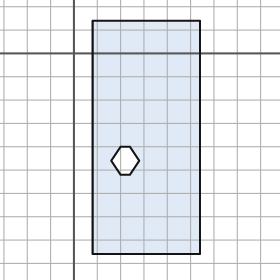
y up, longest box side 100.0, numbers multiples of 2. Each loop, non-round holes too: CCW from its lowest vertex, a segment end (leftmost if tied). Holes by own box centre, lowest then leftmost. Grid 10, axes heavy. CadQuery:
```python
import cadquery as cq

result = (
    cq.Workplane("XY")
    .moveTo(8.0, -86.0)
    .lineTo(54.0, -86.0)
    .lineTo(54.0, 14.0)
    .lineTo(8.0, 14.0)
    .close()
    .moveTo(20.0, -52.0)
    .lineTo(24.0, -52.0)
    .lineTo(28.0, -46.0)
    .lineTo(24.0, -40.0)
    .lineTo(20.0, -40.0)
    .lineTo(16.0, -46.0)
    .close()
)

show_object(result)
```